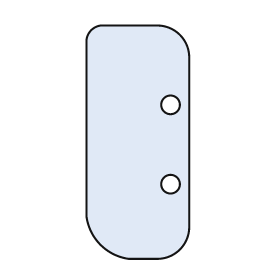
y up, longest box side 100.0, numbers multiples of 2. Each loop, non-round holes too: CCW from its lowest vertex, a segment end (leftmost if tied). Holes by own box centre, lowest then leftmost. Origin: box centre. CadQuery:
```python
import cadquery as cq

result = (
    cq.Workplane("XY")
    .moveTo(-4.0, -50.0)
    .lineTo(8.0, -50.0)
    .threePointArc((18.0, -46.0), (22.0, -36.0))
    .lineTo(22.0, 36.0)
    .threePointArc((18.0, 46.0), (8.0, 50.0))
    .lineTo(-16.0, 50.0)
    .threePointArc((-20.0, 48.0), (-22.0, 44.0))
    .lineTo(-22.0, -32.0)
    .threePointArc((-16.0, -44.0), (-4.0, -50.0))
    .close()
    .moveTo(14.0, -18.0)
    .circle(4.0)
    .moveTo(14.0, 16.0)
    .circle(4.0)
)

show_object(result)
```